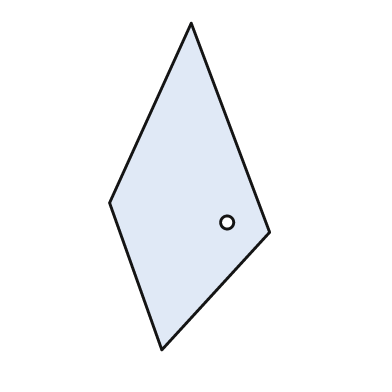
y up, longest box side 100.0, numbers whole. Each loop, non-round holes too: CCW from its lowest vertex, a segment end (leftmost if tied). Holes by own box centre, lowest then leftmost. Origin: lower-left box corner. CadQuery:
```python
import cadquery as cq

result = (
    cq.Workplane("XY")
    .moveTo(16.0, 0.0)
    .lineTo(49.0, 36.0)
    .lineTo(25.0, 100.0)
    .lineTo(0.0, 45.0)
    .close()
    .moveTo(36.0, 39.0)
    .circle(2.0)
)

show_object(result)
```